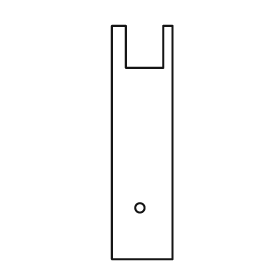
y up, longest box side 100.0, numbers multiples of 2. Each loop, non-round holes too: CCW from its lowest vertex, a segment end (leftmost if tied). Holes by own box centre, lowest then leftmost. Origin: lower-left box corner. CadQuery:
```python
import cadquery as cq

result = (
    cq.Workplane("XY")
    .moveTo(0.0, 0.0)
    .lineTo(26.0, 0.0)
    .lineTo(26.0, 100.0)
    .lineTo(22.0, 100.0)
    .lineTo(22.0, 82.0)
    .lineTo(6.0, 82.0)
    .lineTo(6.0, 100.0)
    .lineTo(0.0, 100.0)
    .close()
    .moveTo(12.0, 22.0)
    .circle(2.0)
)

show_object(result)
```